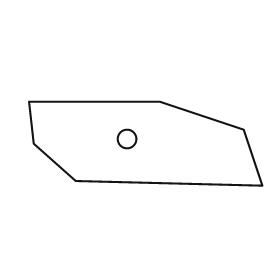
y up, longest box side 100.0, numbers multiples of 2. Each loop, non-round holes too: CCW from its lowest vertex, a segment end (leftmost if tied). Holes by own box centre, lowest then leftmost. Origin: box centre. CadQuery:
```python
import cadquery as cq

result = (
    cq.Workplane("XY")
    .moveTo(50.0, -18.0)
    .lineTo(42.0, 6.0)
    .lineTo(6.0, 18.0)
    .lineTo(-50.0, 18.0)
    .lineTo(-48.0, 0.0)
    .lineTo(-30.0, -16.0)
    .close()
    .moveTo(-8.0, 2.0)
    .circle(4.0)
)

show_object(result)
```